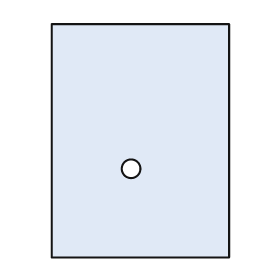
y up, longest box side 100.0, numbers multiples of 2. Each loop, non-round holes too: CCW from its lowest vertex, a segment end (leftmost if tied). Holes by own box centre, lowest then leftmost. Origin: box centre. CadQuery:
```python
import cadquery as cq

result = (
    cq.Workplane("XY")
    .moveTo(-38.0, -50.0)
    .lineTo(38.0, -50.0)
    .lineTo(38.0, 50.0)
    .lineTo(-38.0, 50.0)
    .close()
    .moveTo(-4.0, -12.0)
    .circle(4.0)
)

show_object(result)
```